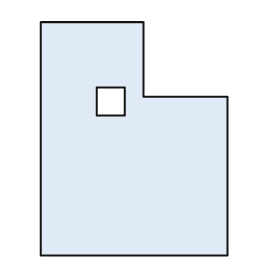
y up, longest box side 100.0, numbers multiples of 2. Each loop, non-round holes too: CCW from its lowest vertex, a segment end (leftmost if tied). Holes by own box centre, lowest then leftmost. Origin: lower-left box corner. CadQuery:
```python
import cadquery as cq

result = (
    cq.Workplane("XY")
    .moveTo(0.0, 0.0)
    .lineTo(80.0, 0.0)
    .lineTo(80.0, 68.0)
    .lineTo(44.0, 68.0)
    .lineTo(44.0, 100.0)
    .lineTo(0.0, 100.0)
    .close()
    .moveTo(24.0, 60.0)
    .lineTo(36.0, 60.0)
    .lineTo(36.0, 72.0)
    .lineTo(24.0, 72.0)
    .close()
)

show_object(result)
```